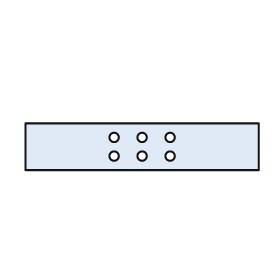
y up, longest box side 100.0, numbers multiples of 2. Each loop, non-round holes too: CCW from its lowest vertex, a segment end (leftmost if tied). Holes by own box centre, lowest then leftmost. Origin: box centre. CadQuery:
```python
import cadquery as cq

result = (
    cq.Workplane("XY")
    .moveTo(-50.0, -10.0)
    .lineTo(50.0, -10.0)
    .lineTo(50.0, 10.0)
    .lineTo(-50.0, 10.0)
    .close()
    .moveTo(-12.0, -4.0)
    .circle(2.0)
    .moveTo(0.0, -4.0)
    .circle(2.0)
    .moveTo(12.0, -4.0)
    .circle(2.0)
    .moveTo(-12.0, 4.0)
    .circle(2.0)
    .moveTo(0.0, 4.0)
    .circle(2.0)
    .moveTo(12.0, 4.0)
    .circle(2.0)
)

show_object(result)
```